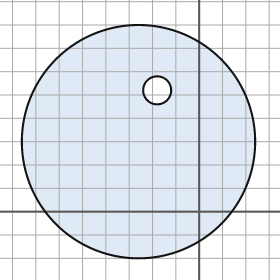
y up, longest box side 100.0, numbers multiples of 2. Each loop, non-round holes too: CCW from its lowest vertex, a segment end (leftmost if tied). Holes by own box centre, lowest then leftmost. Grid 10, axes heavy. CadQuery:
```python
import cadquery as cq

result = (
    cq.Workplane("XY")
    .moveTo(-26.0, 30.0)
    .circle(50.0)
    .moveTo(-18.0, 52.0)
    .circle(6.0)
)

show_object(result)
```